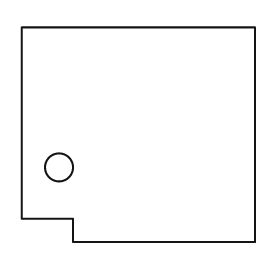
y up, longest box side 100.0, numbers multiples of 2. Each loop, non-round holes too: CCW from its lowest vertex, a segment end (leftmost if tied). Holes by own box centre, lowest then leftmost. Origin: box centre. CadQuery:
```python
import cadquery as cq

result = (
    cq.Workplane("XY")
    .moveTo(-28.0, -46.0)
    .lineTo(50.0, -46.0)
    .lineTo(50.0, 46.0)
    .lineTo(-50.0, 46.0)
    .lineTo(-50.0, -36.0)
    .lineTo(-28.0, -36.0)
    .close()
    .moveTo(-34.0, -14.0)
    .circle(6.0)
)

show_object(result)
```